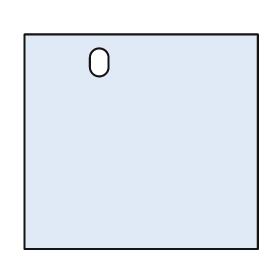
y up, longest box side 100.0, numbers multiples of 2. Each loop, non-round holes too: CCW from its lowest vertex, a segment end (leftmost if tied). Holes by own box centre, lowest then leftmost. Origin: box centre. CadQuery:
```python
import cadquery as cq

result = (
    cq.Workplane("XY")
    .moveTo(-50.0, -46.0)
    .lineTo(50.0, -46.0)
    .lineTo(50.0, 46.0)
    .lineTo(-50.0, 46.0)
    .close()
    .moveTo(-22.0, 32.0)
    .threePointArc((-18.0, 28.0), (-14.0, 32.0))
    .lineTo(-14.0, 36.0)
    .threePointArc((-18.0, 40.0), (-22.0, 36.0))
    .close()
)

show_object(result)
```